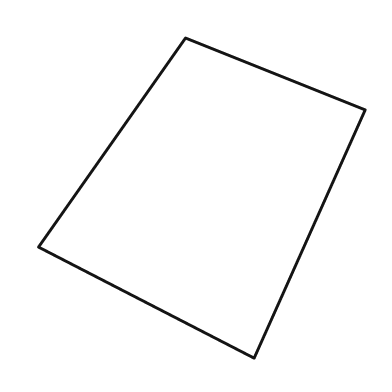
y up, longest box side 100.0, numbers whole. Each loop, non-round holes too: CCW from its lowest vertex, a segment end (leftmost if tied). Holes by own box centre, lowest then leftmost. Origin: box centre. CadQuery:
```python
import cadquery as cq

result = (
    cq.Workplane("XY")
    .moveTo(16.0, -49.0)
    .lineTo(50.0, 27.0)
    .lineTo(-5.0, 49.0)
    .lineTo(-50.0, -15.0)
    .close()
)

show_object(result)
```